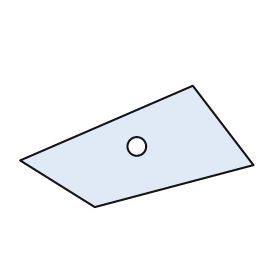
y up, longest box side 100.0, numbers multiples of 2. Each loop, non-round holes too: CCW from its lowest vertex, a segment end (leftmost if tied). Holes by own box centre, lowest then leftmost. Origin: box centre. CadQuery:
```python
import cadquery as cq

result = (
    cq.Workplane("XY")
    .moveTo(-18.0, -26.0)
    .lineTo(50.0, -8.0)
    .lineTo(24.0, 26.0)
    .lineTo(-50.0, -6.0)
    .close()
    .moveTo(0.0, 0.0)
    .circle(4.0)
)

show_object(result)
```